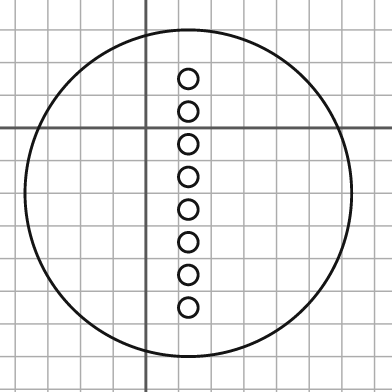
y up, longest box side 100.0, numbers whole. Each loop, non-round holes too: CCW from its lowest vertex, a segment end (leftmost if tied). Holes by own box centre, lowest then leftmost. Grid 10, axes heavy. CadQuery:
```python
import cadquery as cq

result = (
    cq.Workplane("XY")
    .moveTo(13.0, -20.0)
    .circle(50.0)
    .moveTo(13.0, -55.0)
    .circle(3.0)
    .moveTo(13.0, -45.0)
    .circle(3.0)
    .moveTo(13.0, -35.0)
    .circle(3.0)
    .moveTo(13.0, -25.0)
    .circle(3.0)
    .moveTo(13.0, -15.0)
    .circle(3.0)
    .moveTo(13.0, -5.0)
    .circle(3.0)
    .moveTo(13.0, 5.0)
    .circle(3.0)
    .moveTo(13.0, 15.0)
    .circle(3.0)
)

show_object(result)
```